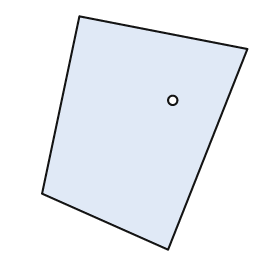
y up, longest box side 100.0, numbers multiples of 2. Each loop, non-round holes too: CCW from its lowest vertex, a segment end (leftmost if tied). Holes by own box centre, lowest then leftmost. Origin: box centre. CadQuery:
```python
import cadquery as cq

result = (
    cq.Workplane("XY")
    .moveTo(10.0, -50.0)
    .lineTo(44.0, 36.0)
    .lineTo(-28.0, 50.0)
    .lineTo(-44.0, -26.0)
    .close()
    .moveTo(12.0, 14.0)
    .circle(2.0)
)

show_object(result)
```